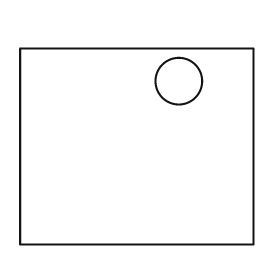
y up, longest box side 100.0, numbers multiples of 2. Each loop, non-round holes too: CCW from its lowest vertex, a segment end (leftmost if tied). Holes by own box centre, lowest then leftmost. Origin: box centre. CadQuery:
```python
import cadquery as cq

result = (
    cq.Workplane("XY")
    .moveTo(-50.0, -42.0)
    .lineTo(50.0, -42.0)
    .lineTo(50.0, 42.0)
    .lineTo(-50.0, 42.0)
    .close()
    .moveTo(18.0, 28.0)
    .circle(10.0)
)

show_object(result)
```